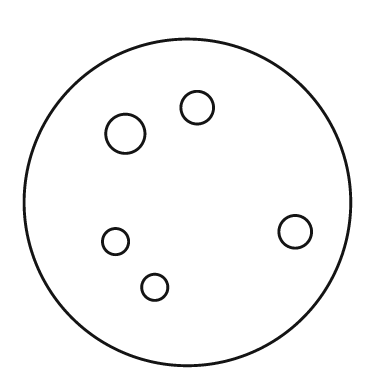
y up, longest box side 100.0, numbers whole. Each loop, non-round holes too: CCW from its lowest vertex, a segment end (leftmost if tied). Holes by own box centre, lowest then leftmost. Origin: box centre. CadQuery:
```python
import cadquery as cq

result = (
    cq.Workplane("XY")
    .moveTo(0.0, 0.0)
    .circle(50.0)
    .moveTo(-10.0, -26.0)
    .circle(4.0)
    .moveTo(-22.0, -12.0)
    .circle(4.0)
    .moveTo(33.0, -9.0)
    .circle(5.0)
    .moveTo(-19.0, 21.0)
    .circle(6.0)
    .moveTo(3.0, 29.0)
    .circle(5.0)
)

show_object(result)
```